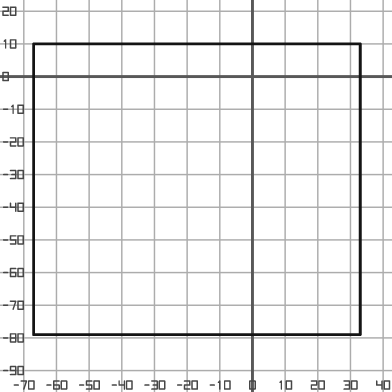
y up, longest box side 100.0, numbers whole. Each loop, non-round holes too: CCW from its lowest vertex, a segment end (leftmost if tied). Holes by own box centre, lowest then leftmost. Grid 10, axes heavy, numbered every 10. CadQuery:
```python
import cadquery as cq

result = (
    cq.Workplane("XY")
    .moveTo(-67.0, -79.0)
    .lineTo(33.0, -79.0)
    .lineTo(33.0, 10.0)
    .lineTo(-67.0, 10.0)
    .close()
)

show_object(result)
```